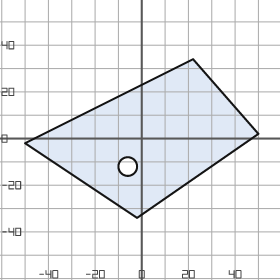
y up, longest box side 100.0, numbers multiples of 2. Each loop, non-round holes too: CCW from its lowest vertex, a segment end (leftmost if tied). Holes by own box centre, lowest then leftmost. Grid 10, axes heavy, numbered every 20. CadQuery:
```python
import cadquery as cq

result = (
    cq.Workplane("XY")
    .moveTo(-2.0, -34.0)
    .lineTo(50.0, 2.0)
    .lineTo(22.0, 34.0)
    .lineTo(-50.0, -2.0)
    .close()
    .moveTo(-6.0, -12.0)
    .circle(4.0)
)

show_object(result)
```